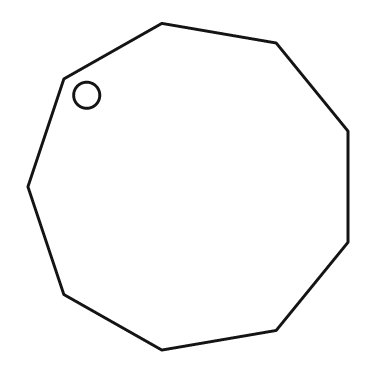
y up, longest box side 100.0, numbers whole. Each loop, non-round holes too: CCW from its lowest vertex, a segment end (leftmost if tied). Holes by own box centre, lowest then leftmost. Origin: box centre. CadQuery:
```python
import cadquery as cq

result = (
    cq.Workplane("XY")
    .moveTo(-8.0, -50.0)
    .lineTo(27.0, -44.0)
    .lineTo(49.0, -17.0)
    .lineTo(49.0, 17.0)
    .lineTo(27.0, 44.0)
    .lineTo(-8.0, 50.0)
    .lineTo(-38.0, 33.0)
    .lineTo(-49.0, 0.0)
    .lineTo(-38.0, -33.0)
    .close()
    .moveTo(-31.0, 28.0)
    .circle(4.0)
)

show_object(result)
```